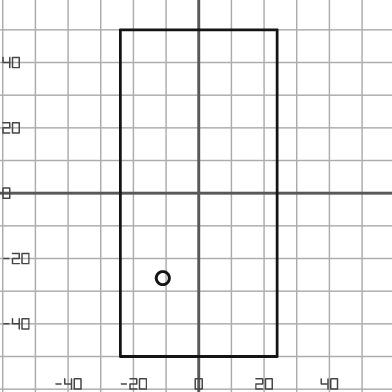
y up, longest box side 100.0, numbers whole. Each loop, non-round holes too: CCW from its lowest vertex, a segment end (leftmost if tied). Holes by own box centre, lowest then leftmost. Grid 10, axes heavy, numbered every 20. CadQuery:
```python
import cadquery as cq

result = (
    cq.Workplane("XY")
    .moveTo(-24.0, -50.0)
    .lineTo(24.0, -50.0)
    .lineTo(24.0, 50.0)
    .lineTo(-24.0, 50.0)
    .close()
    .moveTo(-11.0, -26.0)
    .circle(2.0)
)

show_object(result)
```